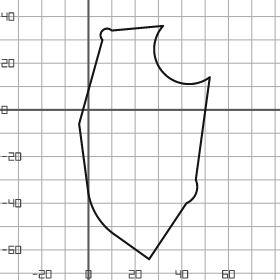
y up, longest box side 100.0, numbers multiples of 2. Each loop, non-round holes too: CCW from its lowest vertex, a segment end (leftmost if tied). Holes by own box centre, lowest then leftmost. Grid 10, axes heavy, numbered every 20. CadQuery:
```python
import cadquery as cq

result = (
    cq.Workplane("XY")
    .moveTo(26.0, -64.0)
    .lineTo(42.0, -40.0)
    .threePointArc((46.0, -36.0), (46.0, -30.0))
    .lineTo(52.0, 14.0)
    .threePointArc((32.0, 16.0), (32.0, 36.0))
    .lineTo(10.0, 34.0)
    .threePointArc((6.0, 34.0), (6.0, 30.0))
    .lineTo(-4.0, -6.0)
    .lineTo(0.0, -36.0)
    .threePointArc((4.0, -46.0), (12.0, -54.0))
    .close()
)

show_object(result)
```